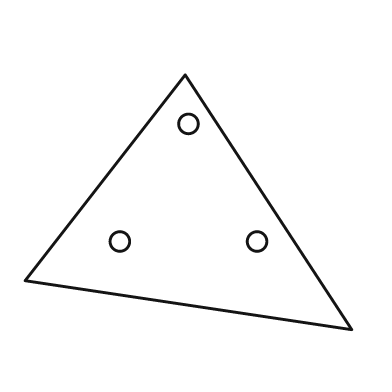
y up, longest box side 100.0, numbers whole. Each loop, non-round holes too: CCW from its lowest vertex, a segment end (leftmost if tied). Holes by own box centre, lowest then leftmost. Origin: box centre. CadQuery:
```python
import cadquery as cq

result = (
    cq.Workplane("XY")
    .moveTo(50.0, -39.0)
    .lineTo(-1.0, 39.0)
    .lineTo(-50.0, -24.0)
    .close()
    .moveTo(-21.0, -12.0)
    .circle(3.0)
    .moveTo(21.0, -12.0)
    .circle(3.0)
    .moveTo(0.0, 24.0)
    .circle(3.0)
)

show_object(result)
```